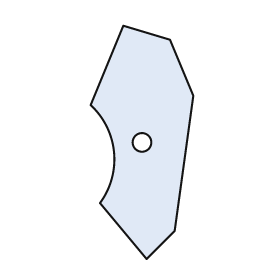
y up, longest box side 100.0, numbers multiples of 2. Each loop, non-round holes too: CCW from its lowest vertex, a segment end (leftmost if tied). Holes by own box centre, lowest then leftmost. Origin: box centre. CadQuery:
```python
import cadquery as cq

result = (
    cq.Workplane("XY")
    .moveTo(2.0, -50.0)
    .lineTo(14.0, -38.0)
    .lineTo(22.0, 20.0)
    .lineTo(12.0, 44.0)
    .lineTo(-8.0, 50.0)
    .lineTo(-22.0, 16.0)
    .threePointArc((-12.0, -4.0), (-18.0, -26.0))
    .close()
    .moveTo(0.0, 0.0)
    .circle(4.0)
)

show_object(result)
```